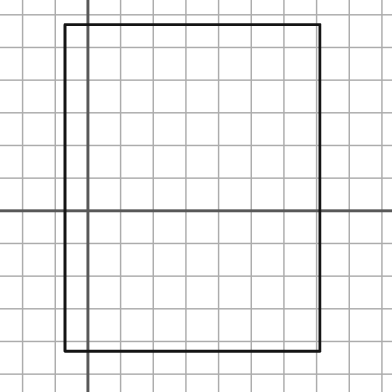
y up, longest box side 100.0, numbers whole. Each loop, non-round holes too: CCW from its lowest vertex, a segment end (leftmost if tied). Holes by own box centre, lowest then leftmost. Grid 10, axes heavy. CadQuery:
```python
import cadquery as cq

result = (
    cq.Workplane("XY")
    .moveTo(-7.0, -43.0)
    .lineTo(71.0, -43.0)
    .lineTo(71.0, 57.0)
    .lineTo(-7.0, 57.0)
    .close()
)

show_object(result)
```